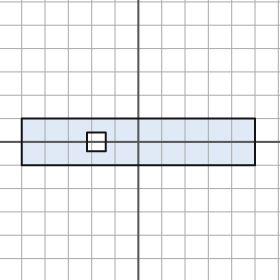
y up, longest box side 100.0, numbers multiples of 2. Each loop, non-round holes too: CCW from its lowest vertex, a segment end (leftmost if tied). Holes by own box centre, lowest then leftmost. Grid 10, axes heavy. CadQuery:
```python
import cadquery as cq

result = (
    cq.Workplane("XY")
    .moveTo(-50.0, -10.0)
    .lineTo(50.0, -10.0)
    .lineTo(50.0, 10.0)
    .lineTo(-50.0, 10.0)
    .close()
    .moveTo(-22.0, -4.0)
    .lineTo(-14.0, -4.0)
    .lineTo(-14.0, 4.0)
    .lineTo(-22.0, 4.0)
    .close()
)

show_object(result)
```